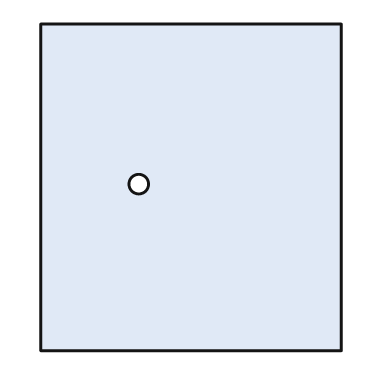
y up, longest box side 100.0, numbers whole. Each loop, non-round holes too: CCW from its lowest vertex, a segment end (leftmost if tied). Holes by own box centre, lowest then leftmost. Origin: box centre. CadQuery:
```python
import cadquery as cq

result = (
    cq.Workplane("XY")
    .moveTo(-46.0, -50.0)
    .lineTo(46.0, -50.0)
    .lineTo(46.0, 50.0)
    .lineTo(-46.0, 50.0)
    .close()
    .moveTo(-16.0, 1.0)
    .circle(3.0)
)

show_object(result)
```